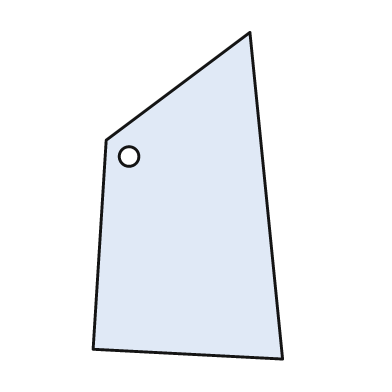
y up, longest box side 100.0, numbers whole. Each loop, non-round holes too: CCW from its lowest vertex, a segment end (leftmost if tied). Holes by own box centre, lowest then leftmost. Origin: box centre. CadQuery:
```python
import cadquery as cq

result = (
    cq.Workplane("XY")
    .moveTo(29.0, -50.0)
    .lineTo(19.0, 50.0)
    .lineTo(-25.0, 17.0)
    .lineTo(-29.0, -47.0)
    .close()
    .moveTo(-18.0, 12.0)
    .circle(3.0)
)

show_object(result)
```